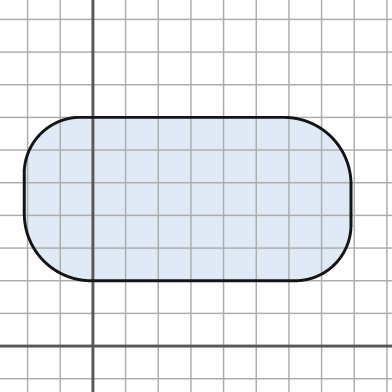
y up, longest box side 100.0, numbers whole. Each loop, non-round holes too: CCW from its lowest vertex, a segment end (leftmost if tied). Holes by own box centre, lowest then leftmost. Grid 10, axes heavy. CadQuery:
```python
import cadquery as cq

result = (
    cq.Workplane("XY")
    .moveTo(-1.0, 20.0)
    .lineTo(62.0, 20.0)
    .threePointArc((74.0, 25.0), (79.0, 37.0))
    .lineTo(79.0, 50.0)
    .threePointArc((73.0, 64.0), (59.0, 70.0))
    .lineTo(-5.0, 70.0)
    .threePointArc((-16.0, 65.0), (-21.0, 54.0))
    .lineTo(-21.0, 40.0)
    .threePointArc((-15.0, 26.0), (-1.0, 20.0))
    .close()
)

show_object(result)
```